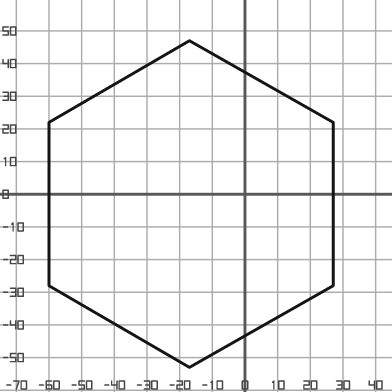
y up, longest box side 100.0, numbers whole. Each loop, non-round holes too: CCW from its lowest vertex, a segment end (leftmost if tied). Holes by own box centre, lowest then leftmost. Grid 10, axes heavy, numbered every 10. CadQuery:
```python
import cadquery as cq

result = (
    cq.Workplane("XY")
    .moveTo(-17.0, -53.0)
    .lineTo(27.0, -28.0)
    .lineTo(27.0, 22.0)
    .lineTo(-17.0, 47.0)
    .lineTo(-60.0, 22.0)
    .lineTo(-60.0, -28.0)
    .close()
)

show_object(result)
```